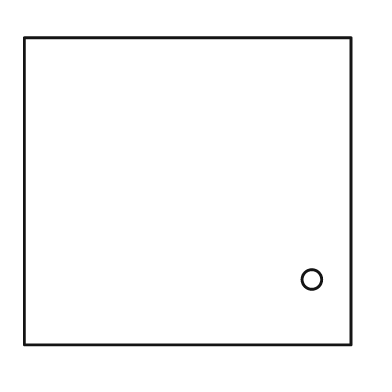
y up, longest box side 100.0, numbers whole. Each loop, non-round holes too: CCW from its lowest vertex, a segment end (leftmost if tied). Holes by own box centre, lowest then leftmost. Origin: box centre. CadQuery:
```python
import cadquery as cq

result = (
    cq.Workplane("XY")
    .moveTo(-50.0, -47.0)
    .lineTo(50.0, -47.0)
    .lineTo(50.0, 47.0)
    .lineTo(-50.0, 47.0)
    .close()
    .moveTo(38.0, -27.0)
    .circle(3.0)
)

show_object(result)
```